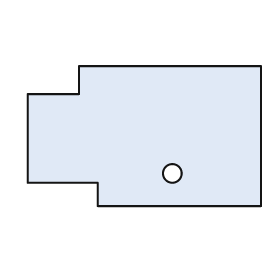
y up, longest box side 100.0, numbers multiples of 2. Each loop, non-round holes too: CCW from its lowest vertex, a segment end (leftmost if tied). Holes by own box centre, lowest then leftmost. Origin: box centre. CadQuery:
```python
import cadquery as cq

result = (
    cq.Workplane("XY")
    .moveTo(-20.0, -30.0)
    .lineTo(50.0, -30.0)
    .lineTo(50.0, 30.0)
    .lineTo(-28.0, 30.0)
    .lineTo(-28.0, 18.0)
    .lineTo(-50.0, 18.0)
    .lineTo(-50.0, -20.0)
    .lineTo(-20.0, -20.0)
    .close()
    .moveTo(12.0, -16.0)
    .circle(4.0)
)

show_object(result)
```